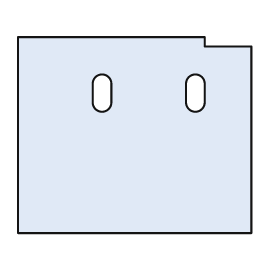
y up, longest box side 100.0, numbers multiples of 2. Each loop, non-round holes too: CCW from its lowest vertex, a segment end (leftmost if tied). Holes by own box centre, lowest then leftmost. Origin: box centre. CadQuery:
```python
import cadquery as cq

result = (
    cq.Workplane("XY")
    .moveTo(-50.0, -42.0)
    .lineTo(50.0, -42.0)
    .lineTo(50.0, 38.0)
    .lineTo(30.0, 38.0)
    .lineTo(30.0, 42.0)
    .lineTo(-50.0, 42.0)
    .close()
    .moveTo(-18.0, 14.0)
    .threePointArc((-14.0, 10.0), (-10.0, 14.0))
    .lineTo(-10.0, 22.0)
    .threePointArc((-14.0, 26.0), (-18.0, 22.0))
    .close()
    .moveTo(22.0, 14.0)
    .threePointArc((26.0, 10.0), (30.0, 14.0))
    .lineTo(30.0, 22.0)
    .threePointArc((26.0, 26.0), (22.0, 22.0))
    .close()
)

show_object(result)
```